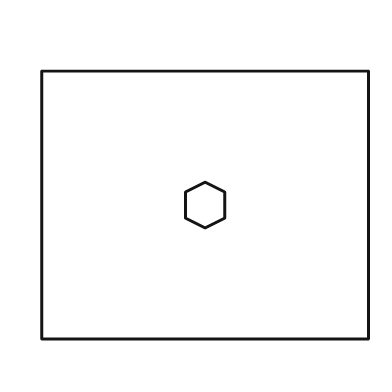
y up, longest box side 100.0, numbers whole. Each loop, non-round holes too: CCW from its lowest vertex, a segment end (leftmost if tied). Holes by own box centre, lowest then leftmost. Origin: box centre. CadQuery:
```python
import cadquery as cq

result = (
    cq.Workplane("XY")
    .moveTo(-50.0, -41.0)
    .lineTo(50.0, -41.0)
    .lineTo(50.0, 41.0)
    .lineTo(-50.0, 41.0)
    .close()
    .moveTo(0.0, -7.0)
    .lineTo(6.0, -4.0)
    .lineTo(6.0, 4.0)
    .lineTo(0.0, 7.0)
    .lineTo(-6.0, 4.0)
    .lineTo(-6.0, -4.0)
    .close()
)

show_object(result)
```